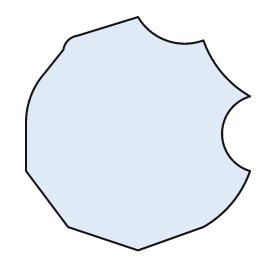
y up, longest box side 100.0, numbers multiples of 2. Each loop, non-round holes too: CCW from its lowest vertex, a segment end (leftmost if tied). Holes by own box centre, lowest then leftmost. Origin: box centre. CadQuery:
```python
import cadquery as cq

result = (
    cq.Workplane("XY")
    .moveTo(0.0, -50.0)
    .lineTo(28.0, -40.0)
    .threePointArc((40.0, -30.0), (48.0, -16.0))
    .threePointArc((36.0, 0.0), (48.0, 16.0))
    .threePointArc((36.0, 26.0), (28.0, 40.0))
    .threePointArc((12.0, 40.0), (0.0, 50.0))
    .lineTo(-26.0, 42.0)
    .threePointArc((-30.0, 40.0), (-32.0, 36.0))
    .lineTo(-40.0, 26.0)
    .threePointArc((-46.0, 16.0), (-48.0, 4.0))
    .lineTo(-48.0, -16.0)
    .lineTo(-30.0, -40.0)
    .close()
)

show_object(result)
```